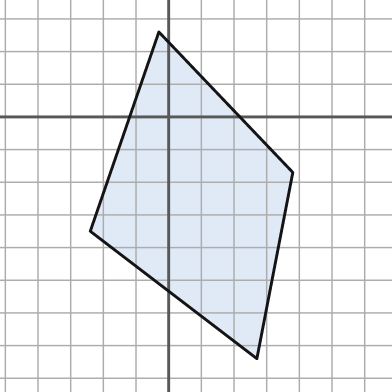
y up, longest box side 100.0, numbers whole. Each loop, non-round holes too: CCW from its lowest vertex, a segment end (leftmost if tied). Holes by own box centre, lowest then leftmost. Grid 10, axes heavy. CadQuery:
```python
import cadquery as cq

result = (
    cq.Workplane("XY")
    .moveTo(27.0, -74.0)
    .lineTo(38.0, -17.0)
    .lineTo(-3.0, 26.0)
    .lineTo(-24.0, -35.0)
    .close()
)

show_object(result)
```